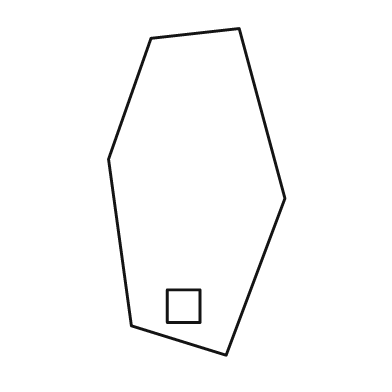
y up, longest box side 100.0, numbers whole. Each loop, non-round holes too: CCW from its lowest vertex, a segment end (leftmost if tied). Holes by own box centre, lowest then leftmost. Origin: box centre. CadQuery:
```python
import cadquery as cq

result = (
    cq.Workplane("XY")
    .moveTo(9.0, -50.0)
    .lineTo(27.0, -2.0)
    .lineTo(13.0, 50.0)
    .lineTo(-14.0, 47.0)
    .lineTo(-27.0, 10.0)
    .lineTo(-20.0, -41.0)
    .close()
    .moveTo(-9.0, -40.0)
    .lineTo(1.0, -40.0)
    .lineTo(1.0, -30.0)
    .lineTo(-9.0, -30.0)
    .close()
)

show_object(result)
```